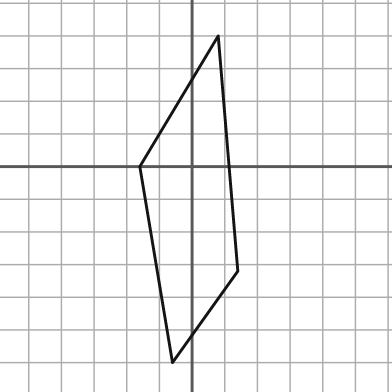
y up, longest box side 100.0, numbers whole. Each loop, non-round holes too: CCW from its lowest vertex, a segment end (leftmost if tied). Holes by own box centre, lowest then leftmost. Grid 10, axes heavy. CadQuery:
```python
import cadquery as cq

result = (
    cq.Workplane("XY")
    .moveTo(-6.0, -60.0)
    .lineTo(14.0, -32.0)
    .lineTo(8.0, 40.0)
    .lineTo(-16.0, 0.0)
    .close()
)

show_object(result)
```